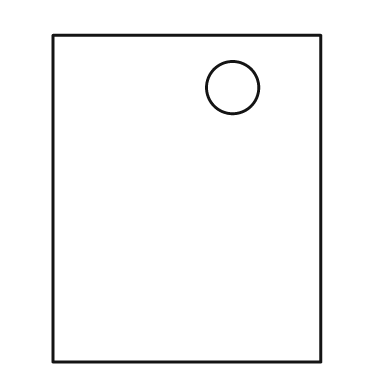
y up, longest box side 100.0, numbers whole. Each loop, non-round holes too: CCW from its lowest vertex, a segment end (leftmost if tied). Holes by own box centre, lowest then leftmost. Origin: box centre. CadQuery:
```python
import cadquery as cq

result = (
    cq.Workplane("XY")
    .moveTo(-41.0, -50.0)
    .lineTo(41.0, -50.0)
    .lineTo(41.0, 50.0)
    .lineTo(-41.0, 50.0)
    .close()
    .moveTo(14.0, 34.0)
    .circle(8.0)
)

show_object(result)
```